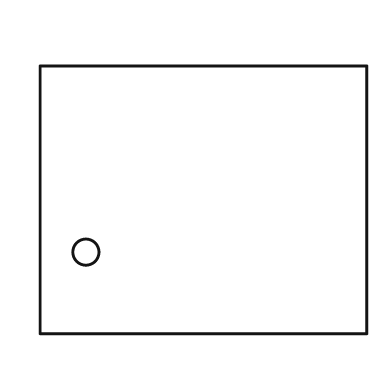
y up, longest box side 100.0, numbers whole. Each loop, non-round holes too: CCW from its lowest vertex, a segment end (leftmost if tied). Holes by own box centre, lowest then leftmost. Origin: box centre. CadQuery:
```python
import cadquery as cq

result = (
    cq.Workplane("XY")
    .moveTo(-50.0, -41.0)
    .lineTo(50.0, -41.0)
    .lineTo(50.0, 41.0)
    .lineTo(-50.0, 41.0)
    .close()
    .moveTo(-36.0, -16.0)
    .circle(4.0)
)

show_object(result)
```